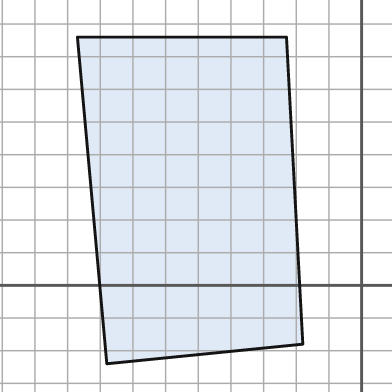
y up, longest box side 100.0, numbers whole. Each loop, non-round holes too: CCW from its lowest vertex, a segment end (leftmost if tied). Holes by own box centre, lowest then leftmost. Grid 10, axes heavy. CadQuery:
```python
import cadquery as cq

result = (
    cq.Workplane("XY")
    .moveTo(-78.0, -24.0)
    .lineTo(-18.0, -18.0)
    .lineTo(-23.0, 76.0)
    .lineTo(-87.0, 76.0)
    .close()
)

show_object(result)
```